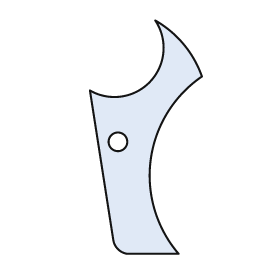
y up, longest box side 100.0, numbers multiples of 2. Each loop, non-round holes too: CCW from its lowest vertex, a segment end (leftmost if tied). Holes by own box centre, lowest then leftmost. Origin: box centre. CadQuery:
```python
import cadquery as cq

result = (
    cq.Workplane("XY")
    .moveTo(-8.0, -50.0)
    .lineTo(14.0, -50.0)
    .threePointArc((2.0, -10.0), (24.0, 26.0))
    .threePointArc((16.0, 40.0), (4.0, 50.0))
    .threePointArc((2.0, 24.0), (-24.0, 20.0))
    .lineTo(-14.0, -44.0)
    .threePointArc((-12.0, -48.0), (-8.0, -50.0))
    .close()
    .moveTo(-12.0, -2.0)
    .circle(4.0)
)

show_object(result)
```